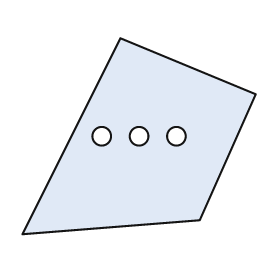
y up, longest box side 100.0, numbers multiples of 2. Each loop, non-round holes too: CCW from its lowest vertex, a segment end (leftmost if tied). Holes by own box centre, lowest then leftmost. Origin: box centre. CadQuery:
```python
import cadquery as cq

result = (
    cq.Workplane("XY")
    .moveTo(-50.0, -42.0)
    .lineTo(26.0, -36.0)
    .lineTo(50.0, 18.0)
    .lineTo(-8.0, 42.0)
    .close()
    .moveTo(-16.0, 0.0)
    .circle(4.0)
    .moveTo(0.0, 0.0)
    .circle(4.0)
    .moveTo(16.0, 0.0)
    .circle(4.0)
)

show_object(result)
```